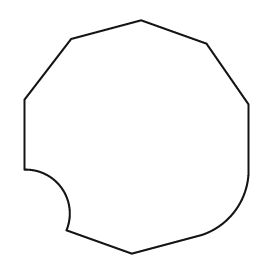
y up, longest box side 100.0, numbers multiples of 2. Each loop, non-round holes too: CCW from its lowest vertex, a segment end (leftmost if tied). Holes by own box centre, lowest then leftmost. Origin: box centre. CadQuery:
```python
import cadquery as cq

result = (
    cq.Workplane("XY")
    .moveTo(-2.0, -50.0)
    .lineTo(28.0, -42.0)
    .threePointArc((42.0, -32.0), (48.0, -16.0))
    .lineTo(48.0, 14.0)
    .lineTo(30.0, 40.0)
    .lineTo(2.0, 50.0)
    .lineTo(-28.0, 42.0)
    .lineTo(-48.0, 16.0)
    .lineTo(-48.0, -14.0)
    .threePointArc((-32.0, -22.0), (-30.0, -40.0))
    .close()
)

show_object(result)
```